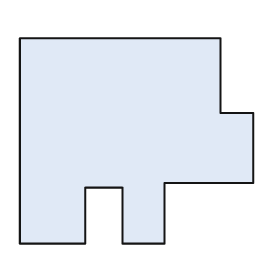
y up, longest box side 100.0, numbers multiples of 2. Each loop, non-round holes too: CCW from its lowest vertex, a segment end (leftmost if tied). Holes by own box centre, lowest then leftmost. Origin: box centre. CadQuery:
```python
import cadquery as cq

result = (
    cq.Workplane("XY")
    .moveTo(-50.0, -44.0)
    .lineTo(-22.0, -44.0)
    .lineTo(-22.0, -20.0)
    .lineTo(-6.0, -20.0)
    .lineTo(-6.0, -44.0)
    .lineTo(12.0, -44.0)
    .lineTo(12.0, -18.0)
    .lineTo(50.0, -18.0)
    .lineTo(50.0, 12.0)
    .lineTo(36.0, 12.0)
    .lineTo(36.0, 44.0)
    .lineTo(-50.0, 44.0)
    .close()
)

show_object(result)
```